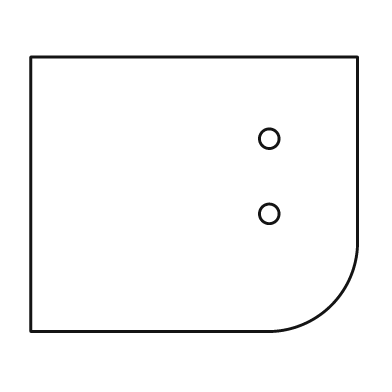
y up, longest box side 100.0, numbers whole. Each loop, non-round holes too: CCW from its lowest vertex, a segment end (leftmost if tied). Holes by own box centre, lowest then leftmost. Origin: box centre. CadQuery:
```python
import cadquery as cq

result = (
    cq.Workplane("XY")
    .moveTo(-50.0, -42.0)
    .lineTo(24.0, -42.0)
    .threePointArc((42.0, -34.0), (50.0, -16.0))
    .lineTo(50.0, 42.0)
    .lineTo(-50.0, 42.0)
    .close()
    .moveTo(23.0, -6.0)
    .circle(3.0)
    .moveTo(23.0, 17.0)
    .circle(3.0)
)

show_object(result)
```